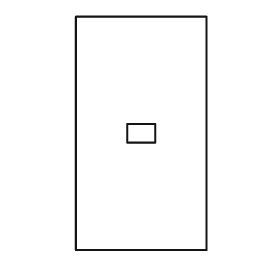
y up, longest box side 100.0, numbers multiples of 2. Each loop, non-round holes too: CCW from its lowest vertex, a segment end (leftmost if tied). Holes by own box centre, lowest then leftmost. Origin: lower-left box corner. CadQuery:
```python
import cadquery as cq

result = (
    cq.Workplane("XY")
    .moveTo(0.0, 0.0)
    .lineTo(56.0, 0.0)
    .lineTo(56.0, 100.0)
    .lineTo(0.0, 100.0)
    .close()
    .moveTo(22.0, 46.0)
    .lineTo(34.0, 46.0)
    .lineTo(34.0, 54.0)
    .lineTo(22.0, 54.0)
    .close()
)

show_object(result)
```